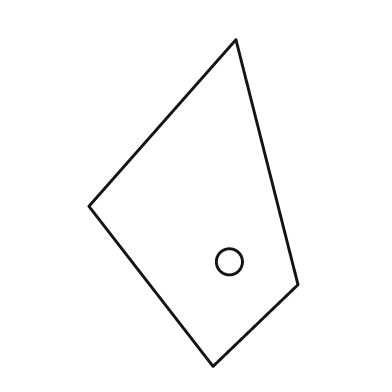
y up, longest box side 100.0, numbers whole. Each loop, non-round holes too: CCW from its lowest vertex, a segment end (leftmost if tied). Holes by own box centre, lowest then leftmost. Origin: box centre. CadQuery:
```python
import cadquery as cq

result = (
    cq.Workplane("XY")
    .moveTo(6.0, -50.0)
    .lineTo(32.0, -25.0)
    .lineTo(13.0, 50.0)
    .lineTo(-32.0, -1.0)
    .close()
    .moveTo(11.0, -18.0)
    .circle(4.0)
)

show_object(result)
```